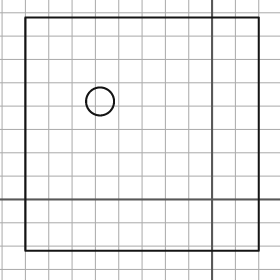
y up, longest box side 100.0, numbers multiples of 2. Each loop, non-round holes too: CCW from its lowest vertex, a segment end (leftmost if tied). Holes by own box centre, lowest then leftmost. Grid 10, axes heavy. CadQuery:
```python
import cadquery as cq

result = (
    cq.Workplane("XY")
    .moveTo(-80.0, -22.0)
    .lineTo(20.0, -22.0)
    .lineTo(20.0, 78.0)
    .lineTo(-80.0, 78.0)
    .close()
    .moveTo(-48.0, 42.0)
    .circle(6.0)
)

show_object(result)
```